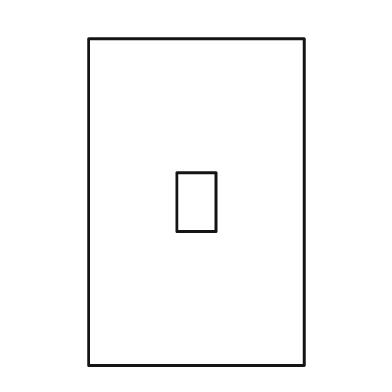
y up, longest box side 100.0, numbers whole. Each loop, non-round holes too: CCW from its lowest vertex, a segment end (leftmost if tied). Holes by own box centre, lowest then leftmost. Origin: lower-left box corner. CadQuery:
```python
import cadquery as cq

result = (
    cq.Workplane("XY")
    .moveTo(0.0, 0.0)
    .lineTo(66.0, 0.0)
    .lineTo(66.0, 100.0)
    .lineTo(0.0, 100.0)
    .close()
    .moveTo(27.0, 41.0)
    .lineTo(39.0, 41.0)
    .lineTo(39.0, 59.0)
    .lineTo(27.0, 59.0)
    .close()
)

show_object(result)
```